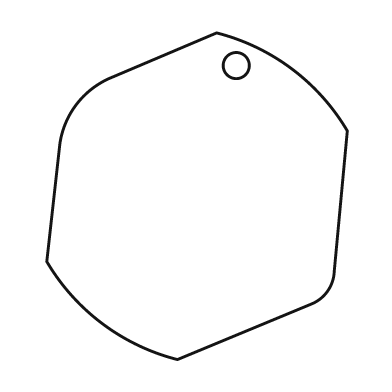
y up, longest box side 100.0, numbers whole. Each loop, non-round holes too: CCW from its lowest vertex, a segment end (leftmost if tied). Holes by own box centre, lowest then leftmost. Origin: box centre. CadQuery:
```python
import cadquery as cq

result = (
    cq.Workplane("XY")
    .moveTo(-6.0, -50.0)
    .lineTo(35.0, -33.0)
    .threePointArc((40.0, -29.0), (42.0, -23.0))
    .lineTo(46.0, 20.0)
    .threePointArc((29.0, 39.0), (6.0, 50.0))
    .lineTo(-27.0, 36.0)
    .threePointArc((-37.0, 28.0), (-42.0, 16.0))
    .lineTo(-46.0, -20.0)
    .threePointArc((-29.0, -39.0), (-6.0, -50.0))
    .close()
    .moveTo(12.0, 40.0)
    .circle(4.0)
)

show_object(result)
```